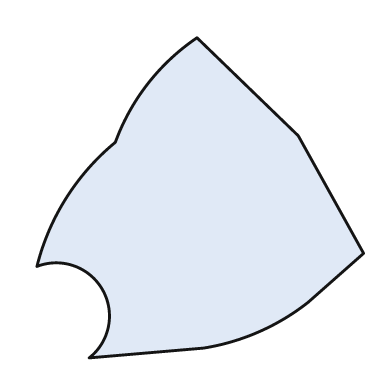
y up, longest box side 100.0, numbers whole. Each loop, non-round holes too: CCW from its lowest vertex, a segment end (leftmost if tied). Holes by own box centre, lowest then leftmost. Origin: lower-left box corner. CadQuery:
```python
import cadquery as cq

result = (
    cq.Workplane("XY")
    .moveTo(16.0, 0.0)
    .lineTo(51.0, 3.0)
    .threePointArc((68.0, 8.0), (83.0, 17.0))
    .lineTo(100.0, 32.0)
    .lineTo(80.0, 68.0)
    .lineTo(49.0, 98.0)
    .threePointArc((34.0, 84.0), (24.0, 66.0))
    .threePointArc((9.0, 49.0), (0.0, 28.0))
    .threePointArc((20.0, 21.0), (16.0, 0.0))
    .close()
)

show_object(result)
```